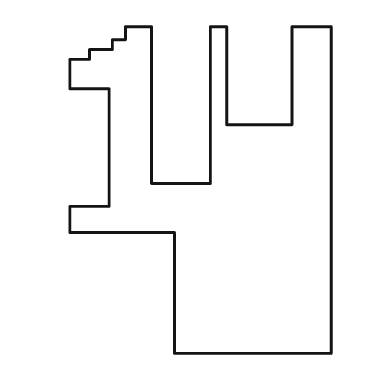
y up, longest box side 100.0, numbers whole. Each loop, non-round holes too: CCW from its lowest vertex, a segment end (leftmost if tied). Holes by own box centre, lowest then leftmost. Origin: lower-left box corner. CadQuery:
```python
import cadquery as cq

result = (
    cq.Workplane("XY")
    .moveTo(32.0, 0.0)
    .lineTo(80.0, 0.0)
    .lineTo(80.0, 100.0)
    .lineTo(68.0, 100.0)
    .lineTo(68.0, 70.0)
    .lineTo(48.0, 70.0)
    .lineTo(48.0, 100.0)
    .lineTo(43.0, 100.0)
    .lineTo(43.0, 52.0)
    .lineTo(25.0, 52.0)
    .lineTo(25.0, 100.0)
    .lineTo(17.0, 100.0)
    .lineTo(17.0, 96.0)
    .lineTo(13.0, 96.0)
    .lineTo(13.0, 93.0)
    .lineTo(6.0, 93.0)
    .lineTo(6.0, 90.0)
    .lineTo(0.0, 90.0)
    .lineTo(0.0, 81.0)
    .lineTo(12.0, 81.0)
    .lineTo(12.0, 45.0)
    .lineTo(0.0, 45.0)
    .lineTo(0.0, 37.0)
    .lineTo(32.0, 37.0)
    .close()
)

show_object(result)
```